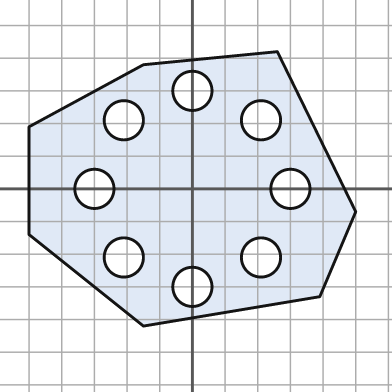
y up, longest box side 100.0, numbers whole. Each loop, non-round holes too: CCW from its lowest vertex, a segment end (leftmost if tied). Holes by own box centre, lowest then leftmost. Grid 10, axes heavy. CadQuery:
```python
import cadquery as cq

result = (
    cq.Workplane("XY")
    .moveTo(-15.0, -42.0)
    .lineTo(39.0, -33.0)
    .lineTo(50.0, -7.0)
    .lineTo(26.0, 42.0)
    .lineTo(-15.0, 38.0)
    .lineTo(-50.0, 19.0)
    .lineTo(-50.0, -14.0)
    .close()
    .moveTo(0.0, -30.0)
    .circle(6.0)
    .moveTo(-21.0, -21.0)
    .circle(6.0)
    .moveTo(21.0, -21.0)
    .circle(6.0)
    .moveTo(-30.0, 0.0)
    .circle(6.0)
    .moveTo(30.0, 0.0)
    .circle(6.0)
    .moveTo(-21.0, 21.0)
    .circle(6.0)
    .moveTo(21.0, 21.0)
    .circle(6.0)
    .moveTo(0.0, 30.0)
    .circle(6.0)
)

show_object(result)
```